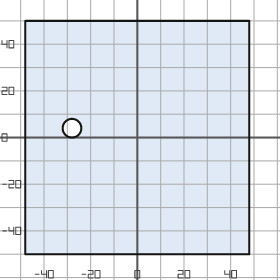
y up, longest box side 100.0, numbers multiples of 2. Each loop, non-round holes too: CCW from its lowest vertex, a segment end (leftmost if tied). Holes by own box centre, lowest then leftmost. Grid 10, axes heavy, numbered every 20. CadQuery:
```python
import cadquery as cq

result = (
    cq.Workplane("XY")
    .moveTo(-48.0, -50.0)
    .lineTo(48.0, -50.0)
    .lineTo(48.0, 50.0)
    .lineTo(-48.0, 50.0)
    .close()
    .moveTo(-28.0, 4.0)
    .circle(4.0)
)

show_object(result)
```